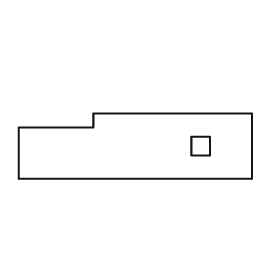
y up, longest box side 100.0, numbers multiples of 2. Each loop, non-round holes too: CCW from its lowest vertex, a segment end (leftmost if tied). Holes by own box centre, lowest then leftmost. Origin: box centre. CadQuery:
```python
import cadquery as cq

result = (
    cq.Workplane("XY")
    .moveTo(-50.0, -14.0)
    .lineTo(50.0, -14.0)
    .lineTo(50.0, 14.0)
    .lineTo(-18.0, 14.0)
    .lineTo(-18.0, 8.0)
    .lineTo(-50.0, 8.0)
    .close()
    .moveTo(24.0, -4.0)
    .lineTo(32.0, -4.0)
    .lineTo(32.0, 4.0)
    .lineTo(24.0, 4.0)
    .close()
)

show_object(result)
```